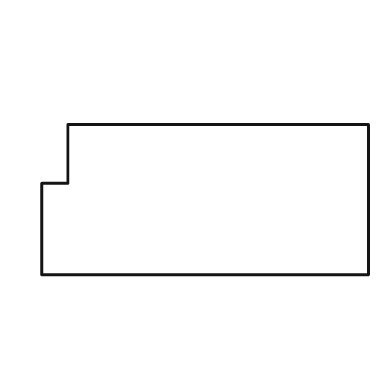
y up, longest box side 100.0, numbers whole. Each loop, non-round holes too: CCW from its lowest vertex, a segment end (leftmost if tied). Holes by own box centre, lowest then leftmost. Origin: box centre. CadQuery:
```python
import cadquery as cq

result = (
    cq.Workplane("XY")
    .moveTo(-50.0, -23.0)
    .lineTo(50.0, -23.0)
    .lineTo(50.0, 23.0)
    .lineTo(-42.0, 23.0)
    .lineTo(-42.0, 5.0)
    .lineTo(-50.0, 5.0)
    .close()
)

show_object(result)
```